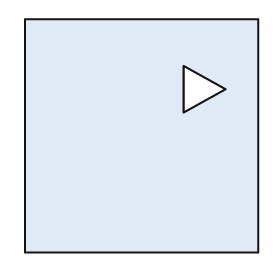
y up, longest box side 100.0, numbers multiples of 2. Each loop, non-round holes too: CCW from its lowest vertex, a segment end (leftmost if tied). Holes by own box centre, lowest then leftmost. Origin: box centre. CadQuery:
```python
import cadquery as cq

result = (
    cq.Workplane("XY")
    .moveTo(-50.0, -50.0)
    .lineTo(50.0, -50.0)
    .lineTo(50.0, 50.0)
    .lineTo(-50.0, 50.0)
    .close()
    .moveTo(18.0, 10.0)
    .lineTo(36.0, 20.0)
    .lineTo(18.0, 30.0)
    .close()
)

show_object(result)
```